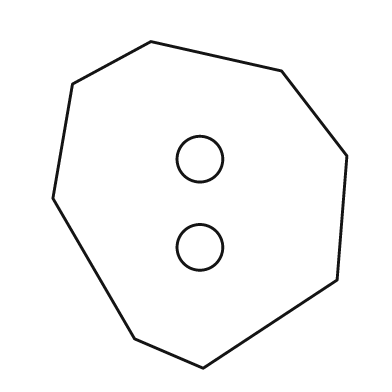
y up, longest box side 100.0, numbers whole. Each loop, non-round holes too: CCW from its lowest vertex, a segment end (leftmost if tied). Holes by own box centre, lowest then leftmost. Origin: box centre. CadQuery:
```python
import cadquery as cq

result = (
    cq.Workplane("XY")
    .moveTo(1.0, -50.0)
    .lineTo(42.0, -23.0)
    .lineTo(45.0, 15.0)
    .lineTo(25.0, 41.0)
    .lineTo(-15.0, 50.0)
    .lineTo(-39.0, 37.0)
    .lineTo(-45.0, 2.0)
    .lineTo(-20.0, -41.0)
    .close()
    .moveTo(0.0, -13.0)
    .circle(7.0)
    .moveTo(0.0, 14.0)
    .circle(7.0)
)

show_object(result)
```